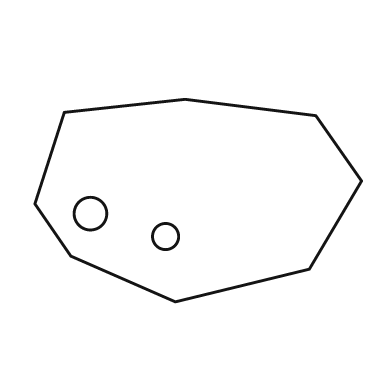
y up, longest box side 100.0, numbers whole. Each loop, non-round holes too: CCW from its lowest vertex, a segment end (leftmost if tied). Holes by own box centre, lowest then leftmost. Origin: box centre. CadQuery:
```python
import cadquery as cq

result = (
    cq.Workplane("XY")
    .moveTo(-7.0, -31.0)
    .lineTo(34.0, -21.0)
    .lineTo(50.0, 6.0)
    .lineTo(36.0, 26.0)
    .lineTo(-4.0, 31.0)
    .lineTo(-41.0, 27.0)
    .lineTo(-50.0, -1.0)
    .lineTo(-39.0, -17.0)
    .close()
    .moveTo(-10.0, -11.0)
    .circle(4.0)
    .moveTo(-33.0, -4.0)
    .circle(5.0)
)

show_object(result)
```